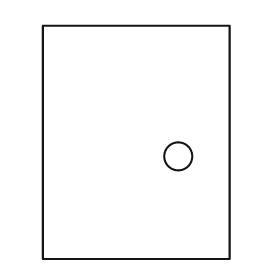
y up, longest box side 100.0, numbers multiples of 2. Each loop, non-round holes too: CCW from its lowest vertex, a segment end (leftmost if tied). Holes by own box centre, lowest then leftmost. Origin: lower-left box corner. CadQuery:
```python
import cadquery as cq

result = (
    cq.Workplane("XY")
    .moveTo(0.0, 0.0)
    .lineTo(80.0, 0.0)
    .lineTo(80.0, 100.0)
    .lineTo(0.0, 100.0)
    .close()
    .moveTo(58.0, 44.0)
    .circle(6.0)
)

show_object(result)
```